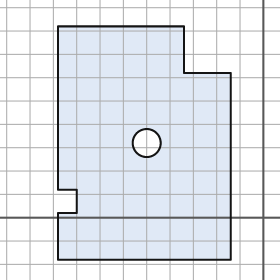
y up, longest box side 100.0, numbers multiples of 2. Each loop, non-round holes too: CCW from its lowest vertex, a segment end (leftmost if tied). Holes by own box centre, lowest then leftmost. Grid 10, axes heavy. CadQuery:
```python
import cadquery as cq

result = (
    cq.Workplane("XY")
    .moveTo(-88.0, -18.0)
    .lineTo(-14.0, -18.0)
    .lineTo(-14.0, 62.0)
    .lineTo(-34.0, 62.0)
    .lineTo(-34.0, 82.0)
    .lineTo(-88.0, 82.0)
    .lineTo(-88.0, 12.0)
    .lineTo(-80.0, 12.0)
    .lineTo(-80.0, 2.0)
    .lineTo(-88.0, 2.0)
    .close()
    .moveTo(-50.0, 32.0)
    .circle(6.0)
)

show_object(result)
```